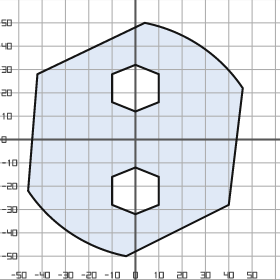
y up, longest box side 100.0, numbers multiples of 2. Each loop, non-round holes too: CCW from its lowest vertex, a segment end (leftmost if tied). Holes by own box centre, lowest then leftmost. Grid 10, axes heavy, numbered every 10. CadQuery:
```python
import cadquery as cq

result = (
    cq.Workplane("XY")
    .moveTo(-4.0, -50.0)
    .lineTo(40.0, -28.0)
    .lineTo(46.0, 22.0)
    .threePointArc((28.0, 40.0), (4.0, 50.0))
    .lineTo(-42.0, 28.0)
    .lineTo(-46.0, -22.0)
    .threePointArc((-28.0, -40.0), (-4.0, -50.0))
    .close()
    .moveTo(0.0, -32.0)
    .lineTo(10.0, -28.0)
    .lineTo(10.0, -16.0)
    .lineTo(0.0, -12.0)
    .lineTo(-10.0, -16.0)
    .lineTo(-10.0, -28.0)
    .close()
    .moveTo(0.0, 12.0)
    .lineTo(10.0, 16.0)
    .lineTo(10.0, 28.0)
    .lineTo(0.0, 32.0)
    .lineTo(-10.0, 28.0)
    .lineTo(-10.0, 16.0)
    .close()
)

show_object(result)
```